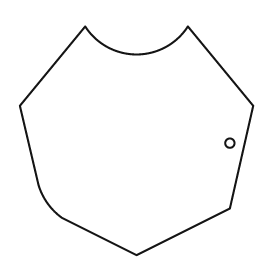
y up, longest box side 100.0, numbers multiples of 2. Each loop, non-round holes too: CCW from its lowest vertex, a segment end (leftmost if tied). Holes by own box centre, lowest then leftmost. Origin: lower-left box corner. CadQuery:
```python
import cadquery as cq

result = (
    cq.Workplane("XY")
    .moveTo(50.0, 0.0)
    .lineTo(90.0, 20.0)
    .lineTo(100.0, 64.0)
    .lineTo(72.0, 98.0)
    .threePointArc((50.0, 86.0), (28.0, 98.0))
    .lineTo(0.0, 64.0)
    .lineTo(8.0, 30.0)
    .threePointArc((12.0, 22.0), (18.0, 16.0))
    .close()
    .moveTo(90.0, 48.0)
    .circle(2.0)
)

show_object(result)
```